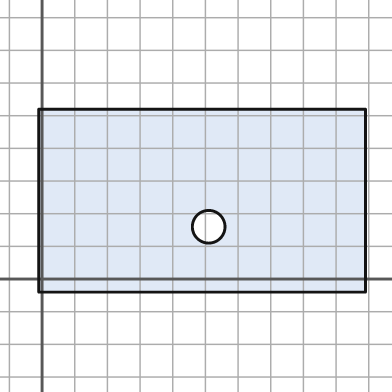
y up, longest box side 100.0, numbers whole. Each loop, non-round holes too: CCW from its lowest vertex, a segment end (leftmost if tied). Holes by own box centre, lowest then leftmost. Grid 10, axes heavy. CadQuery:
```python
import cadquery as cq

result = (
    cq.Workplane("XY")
    .moveTo(-1.0, -4.0)
    .lineTo(99.0, -4.0)
    .lineTo(99.0, 52.0)
    .lineTo(-1.0, 52.0)
    .close()
    .moveTo(51.0, 16.0)
    .circle(5.0)
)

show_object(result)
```